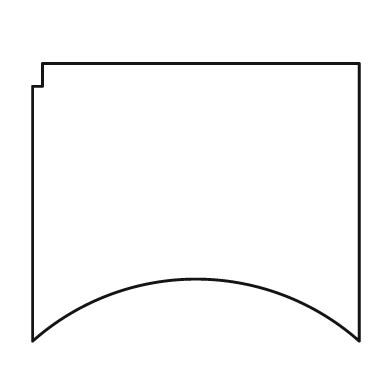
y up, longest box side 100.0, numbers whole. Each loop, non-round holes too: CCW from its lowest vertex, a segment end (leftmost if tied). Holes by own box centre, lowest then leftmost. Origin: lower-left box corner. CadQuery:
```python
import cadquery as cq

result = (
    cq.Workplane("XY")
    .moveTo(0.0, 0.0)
    .threePointArc((50.0, 19.0), (100.0, 0.0))
    .lineTo(100.0, 85.0)
    .lineTo(3.0, 85.0)
    .lineTo(3.0, 78.0)
    .lineTo(0.0, 78.0)
    .close()
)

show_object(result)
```